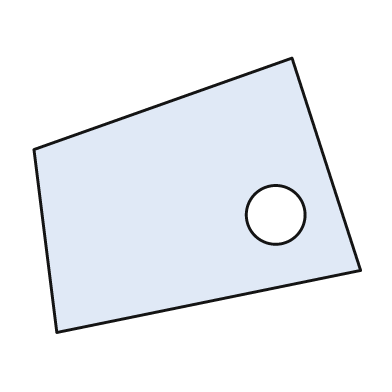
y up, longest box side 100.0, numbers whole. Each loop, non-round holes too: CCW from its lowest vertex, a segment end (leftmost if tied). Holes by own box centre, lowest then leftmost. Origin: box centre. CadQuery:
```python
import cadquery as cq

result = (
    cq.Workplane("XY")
    .moveTo(-43.0, -42.0)
    .lineTo(50.0, -23.0)
    .lineTo(29.0, 42.0)
    .lineTo(-50.0, 14.0)
    .close()
    .moveTo(24.0, -6.0)
    .circle(9.0)
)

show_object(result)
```